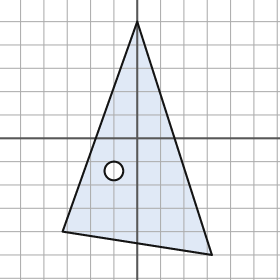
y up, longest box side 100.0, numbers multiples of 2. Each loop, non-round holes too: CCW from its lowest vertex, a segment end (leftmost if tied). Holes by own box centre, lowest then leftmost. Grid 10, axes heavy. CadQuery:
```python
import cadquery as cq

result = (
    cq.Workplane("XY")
    .moveTo(32.0, -50.0)
    .lineTo(0.0, 50.0)
    .lineTo(-32.0, -40.0)
    .close()
    .moveTo(-10.0, -14.0)
    .circle(4.0)
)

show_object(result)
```